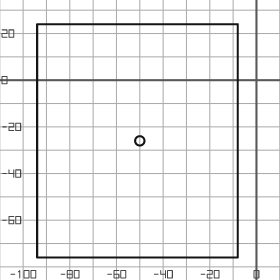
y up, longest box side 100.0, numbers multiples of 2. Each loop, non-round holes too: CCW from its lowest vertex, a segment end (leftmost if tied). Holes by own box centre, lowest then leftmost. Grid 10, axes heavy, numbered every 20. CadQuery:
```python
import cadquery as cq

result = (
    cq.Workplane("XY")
    .moveTo(-94.0, -76.0)
    .lineTo(-8.0, -76.0)
    .lineTo(-8.0, 24.0)
    .lineTo(-94.0, 24.0)
    .close()
    .moveTo(-50.0, -26.0)
    .circle(2.0)
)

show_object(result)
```